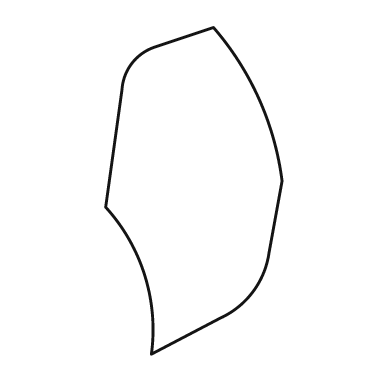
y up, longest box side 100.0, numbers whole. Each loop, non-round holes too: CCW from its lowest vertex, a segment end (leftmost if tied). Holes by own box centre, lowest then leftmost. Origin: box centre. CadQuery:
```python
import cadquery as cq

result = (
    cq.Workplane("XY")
    .moveTo(-13.0, -50.0)
    .lineTo(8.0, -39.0)
    .threePointArc((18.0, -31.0), (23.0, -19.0))
    .lineTo(27.0, 3.0)
    .threePointArc((20.0, 28.0), (6.0, 50.0))
    .lineTo(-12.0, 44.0)
    .threePointArc((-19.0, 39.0), (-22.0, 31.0))
    .lineTo(-27.0, -5.0)
    .threePointArc((-15.0, -26.0), (-13.0, -50.0))
    .close()
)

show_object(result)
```